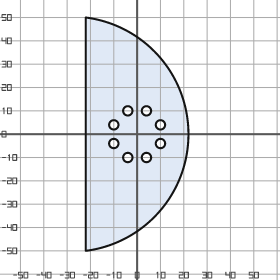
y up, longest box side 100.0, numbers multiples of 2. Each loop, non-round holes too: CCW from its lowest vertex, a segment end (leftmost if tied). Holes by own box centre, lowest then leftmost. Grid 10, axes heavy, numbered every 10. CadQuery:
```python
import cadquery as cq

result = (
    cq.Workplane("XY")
    .moveTo(-22.0, -50.0)
    .threePointArc((22.0, 0.0), (-22.0, 50.0))
    .close()
    .moveTo(-4.0, -10.0)
    .circle(2.0)
    .moveTo(4.0, -10.0)
    .circle(2.0)
    .moveTo(-10.0, -4.0)
    .circle(2.0)
    .moveTo(10.0, -4.0)
    .circle(2.0)
    .moveTo(-10.0, 4.0)
    .circle(2.0)
    .moveTo(10.0, 4.0)
    .circle(2.0)
    .moveTo(-4.0, 10.0)
    .circle(2.0)
    .moveTo(4.0, 10.0)
    .circle(2.0)
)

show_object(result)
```